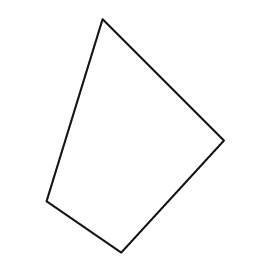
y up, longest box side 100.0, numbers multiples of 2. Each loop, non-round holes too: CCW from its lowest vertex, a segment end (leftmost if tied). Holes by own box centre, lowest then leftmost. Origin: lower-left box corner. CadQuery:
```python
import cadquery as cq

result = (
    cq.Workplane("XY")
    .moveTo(32.0, 0.0)
    .lineTo(76.0, 48.0)
    .lineTo(24.0, 100.0)
    .lineTo(0.0, 22.0)
    .close()
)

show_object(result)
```